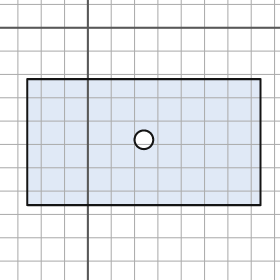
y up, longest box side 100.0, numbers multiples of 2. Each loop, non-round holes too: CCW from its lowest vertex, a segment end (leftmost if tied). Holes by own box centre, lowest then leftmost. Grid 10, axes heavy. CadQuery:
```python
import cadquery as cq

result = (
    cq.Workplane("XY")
    .moveTo(-26.0, -76.0)
    .lineTo(74.0, -76.0)
    .lineTo(74.0, -22.0)
    .lineTo(-26.0, -22.0)
    .close()
    .moveTo(24.0, -48.0)
    .circle(4.0)
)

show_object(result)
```